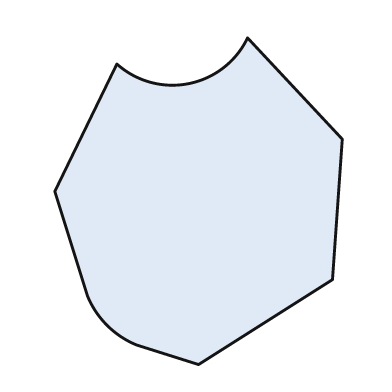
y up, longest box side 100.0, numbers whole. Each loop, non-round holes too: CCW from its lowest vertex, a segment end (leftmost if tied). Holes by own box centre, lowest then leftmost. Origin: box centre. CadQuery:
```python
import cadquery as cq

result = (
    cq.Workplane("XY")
    .moveTo(0.0, -50.0)
    .lineTo(41.0, -24.0)
    .lineTo(44.0, 19.0)
    .lineTo(15.0, 50.0)
    .threePointArc((-3.0, 36.0), (-25.0, 42.0))
    .lineTo(-44.0, 3.0)
    .lineTo(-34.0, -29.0)
    .threePointArc((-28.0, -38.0), (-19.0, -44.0))
    .close()
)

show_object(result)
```